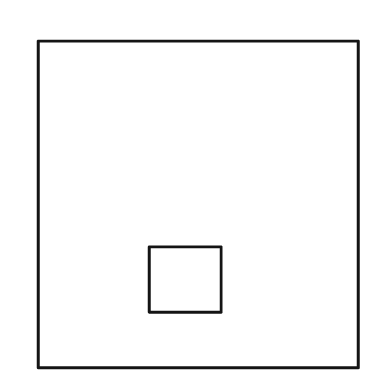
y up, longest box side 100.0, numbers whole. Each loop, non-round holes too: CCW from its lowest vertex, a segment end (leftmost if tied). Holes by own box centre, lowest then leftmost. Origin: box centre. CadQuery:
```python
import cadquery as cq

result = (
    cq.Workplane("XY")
    .moveTo(-49.0, -50.0)
    .lineTo(49.0, -50.0)
    .lineTo(49.0, 50.0)
    .lineTo(-49.0, 50.0)
    .close()
    .moveTo(-15.0, -33.0)
    .lineTo(7.0, -33.0)
    .lineTo(7.0, -13.0)
    .lineTo(-15.0, -13.0)
    .close()
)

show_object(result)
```